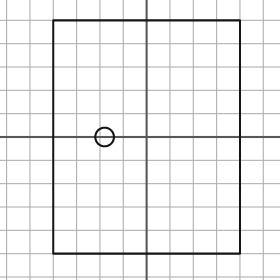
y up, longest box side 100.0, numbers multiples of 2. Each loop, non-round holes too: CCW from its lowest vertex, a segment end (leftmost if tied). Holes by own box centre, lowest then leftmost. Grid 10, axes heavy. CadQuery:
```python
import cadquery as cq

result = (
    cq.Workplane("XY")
    .moveTo(-40.0, -50.0)
    .lineTo(40.0, -50.0)
    .lineTo(40.0, 50.0)
    .lineTo(-40.0, 50.0)
    .close()
    .moveTo(-18.0, 0.0)
    .circle(4.0)
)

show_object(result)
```